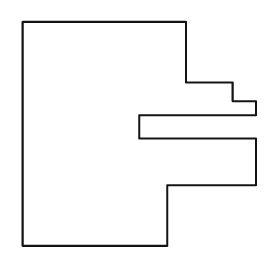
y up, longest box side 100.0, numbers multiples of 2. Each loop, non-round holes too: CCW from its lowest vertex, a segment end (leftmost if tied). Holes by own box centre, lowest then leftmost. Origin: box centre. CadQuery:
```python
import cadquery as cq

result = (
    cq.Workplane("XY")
    .moveTo(-50.0, -48.0)
    .lineTo(12.0, -48.0)
    .lineTo(12.0, -22.0)
    .lineTo(50.0, -22.0)
    .lineTo(50.0, -2.0)
    .lineTo(0.0, -2.0)
    .lineTo(0.0, 8.0)
    .lineTo(50.0, 8.0)
    .lineTo(50.0, 14.0)
    .lineTo(40.0, 14.0)
    .lineTo(40.0, 22.0)
    .lineTo(20.0, 22.0)
    .lineTo(20.0, 48.0)
    .lineTo(-50.0, 48.0)
    .close()
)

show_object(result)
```